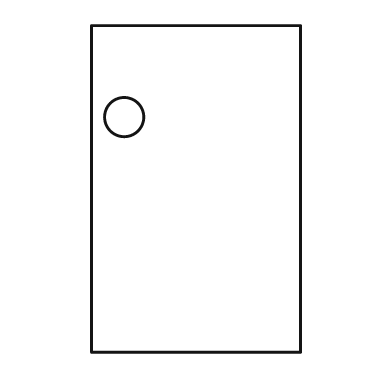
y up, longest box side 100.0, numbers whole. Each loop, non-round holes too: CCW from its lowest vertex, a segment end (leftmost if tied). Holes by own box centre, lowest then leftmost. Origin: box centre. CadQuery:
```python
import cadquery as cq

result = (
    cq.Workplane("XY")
    .moveTo(-32.0, -50.0)
    .lineTo(32.0, -50.0)
    .lineTo(32.0, 50.0)
    .lineTo(-32.0, 50.0)
    .close()
    .moveTo(-22.0, 22.0)
    .circle(6.0)
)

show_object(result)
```